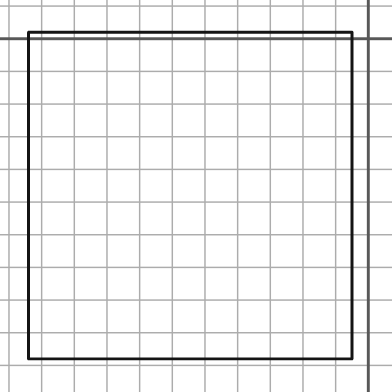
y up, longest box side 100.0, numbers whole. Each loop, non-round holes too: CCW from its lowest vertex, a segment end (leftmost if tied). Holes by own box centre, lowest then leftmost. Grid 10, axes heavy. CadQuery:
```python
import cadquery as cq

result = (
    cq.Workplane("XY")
    .moveTo(-104.0, -98.0)
    .lineTo(-5.0, -98.0)
    .lineTo(-5.0, 2.0)
    .lineTo(-104.0, 2.0)
    .close()
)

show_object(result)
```